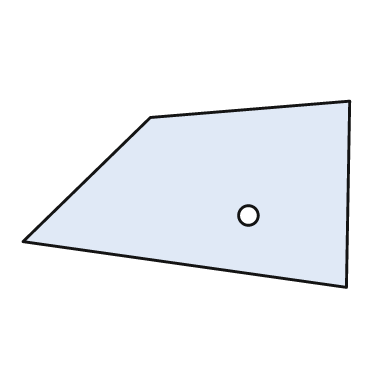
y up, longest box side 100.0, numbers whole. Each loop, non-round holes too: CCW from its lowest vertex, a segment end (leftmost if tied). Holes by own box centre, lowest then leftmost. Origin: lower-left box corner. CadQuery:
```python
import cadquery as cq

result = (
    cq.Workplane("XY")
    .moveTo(99.0, 0.0)
    .lineTo(100.0, 57.0)
    .lineTo(39.0, 52.0)
    .lineTo(0.0, 14.0)
    .close()
    .moveTo(69.0, 22.0)
    .circle(3.0)
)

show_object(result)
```